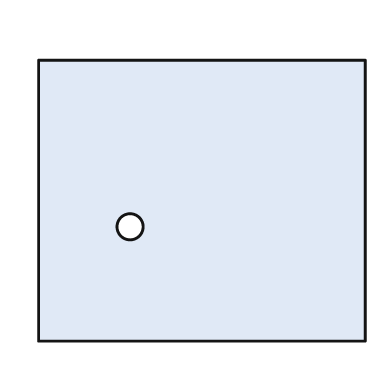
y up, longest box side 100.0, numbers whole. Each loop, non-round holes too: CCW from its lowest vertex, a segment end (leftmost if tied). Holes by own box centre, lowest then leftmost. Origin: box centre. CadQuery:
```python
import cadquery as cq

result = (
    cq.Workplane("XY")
    .moveTo(-50.0, -43.0)
    .lineTo(50.0, -43.0)
    .lineTo(50.0, 43.0)
    .lineTo(-50.0, 43.0)
    .close()
    .moveTo(-22.0, -8.0)
    .circle(4.0)
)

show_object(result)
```